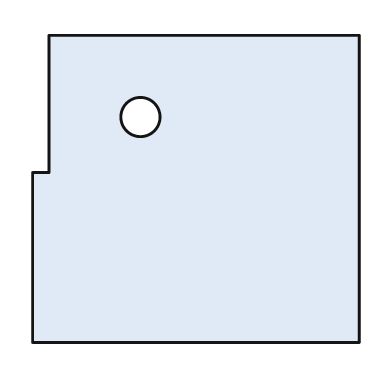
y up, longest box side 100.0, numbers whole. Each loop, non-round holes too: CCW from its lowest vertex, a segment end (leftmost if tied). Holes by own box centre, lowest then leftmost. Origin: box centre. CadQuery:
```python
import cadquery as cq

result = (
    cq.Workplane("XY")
    .moveTo(-50.0, -47.0)
    .lineTo(50.0, -47.0)
    .lineTo(50.0, 47.0)
    .lineTo(-45.0, 47.0)
    .lineTo(-45.0, 5.0)
    .lineTo(-50.0, 5.0)
    .close()
    .moveTo(-17.0, 22.0)
    .circle(6.0)
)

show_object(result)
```